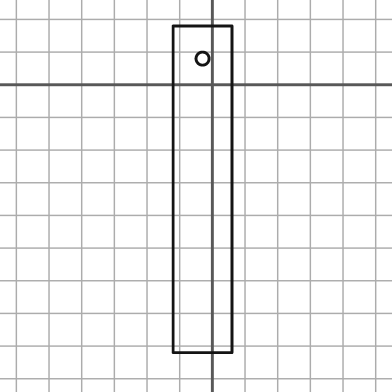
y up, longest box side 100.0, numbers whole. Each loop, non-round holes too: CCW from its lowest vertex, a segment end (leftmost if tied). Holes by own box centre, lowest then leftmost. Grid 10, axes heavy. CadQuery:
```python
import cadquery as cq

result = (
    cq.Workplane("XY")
    .moveTo(-12.0, -82.0)
    .lineTo(6.0, -82.0)
    .lineTo(6.0, 18.0)
    .lineTo(-12.0, 18.0)
    .close()
    .moveTo(-3.0, 8.0)
    .circle(2.0)
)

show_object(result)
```